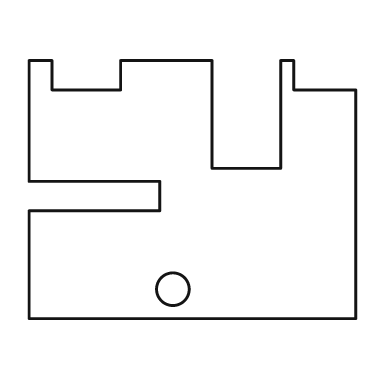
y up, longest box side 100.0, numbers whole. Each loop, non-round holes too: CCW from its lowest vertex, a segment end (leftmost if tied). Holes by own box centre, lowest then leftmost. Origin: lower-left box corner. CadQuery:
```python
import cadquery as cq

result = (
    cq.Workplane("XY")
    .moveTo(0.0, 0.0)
    .lineTo(100.0, 0.0)
    .lineTo(100.0, 70.0)
    .lineTo(81.0, 70.0)
    .lineTo(81.0, 79.0)
    .lineTo(77.0, 79.0)
    .lineTo(77.0, 46.0)
    .lineTo(56.0, 46.0)
    .lineTo(56.0, 79.0)
    .lineTo(28.0, 79.0)
    .lineTo(28.0, 70.0)
    .lineTo(7.0, 70.0)
    .lineTo(7.0, 79.0)
    .lineTo(0.0, 79.0)
    .lineTo(0.0, 42.0)
    .lineTo(40.0, 42.0)
    .lineTo(40.0, 33.0)
    .lineTo(0.0, 33.0)
    .close()
    .moveTo(44.0, 9.0)
    .circle(5.0)
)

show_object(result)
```